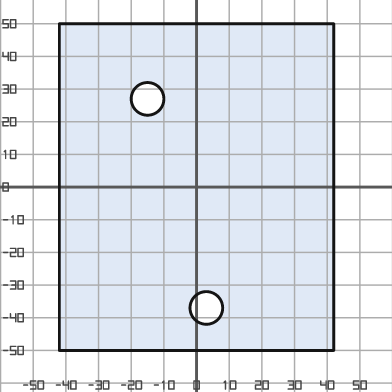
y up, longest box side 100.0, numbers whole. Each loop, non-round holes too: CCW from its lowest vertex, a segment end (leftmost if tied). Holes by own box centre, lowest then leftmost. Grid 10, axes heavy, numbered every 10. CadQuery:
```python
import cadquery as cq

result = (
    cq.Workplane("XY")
    .moveTo(-42.0, -50.0)
    .lineTo(42.0, -50.0)
    .lineTo(42.0, 50.0)
    .lineTo(-42.0, 50.0)
    .close()
    .moveTo(3.0, -37.0)
    .circle(5.0)
    .moveTo(-15.0, 27.0)
    .circle(5.0)
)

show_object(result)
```